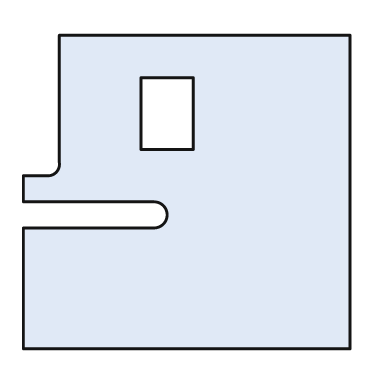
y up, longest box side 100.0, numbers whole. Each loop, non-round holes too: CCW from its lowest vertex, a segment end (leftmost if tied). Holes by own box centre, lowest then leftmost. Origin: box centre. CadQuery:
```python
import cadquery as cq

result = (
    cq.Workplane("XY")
    .moveTo(-50.0, -48.0)
    .lineTo(50.0, -48.0)
    .lineTo(50.0, 48.0)
    .lineTo(-39.0, 48.0)
    .lineTo(-39.0, 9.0)
    .threePointArc((-40.0, 6.0), (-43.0, 5.0))
    .lineTo(-50.0, 5.0)
    .lineTo(-50.0, -3.0)
    .lineTo(-10.0, -3.0)
    .threePointArc((-6.0, -7.0), (-10.0, -11.0))
    .lineTo(-50.0, -11.0)
    .close()
    .moveTo(-14.0, 13.0)
    .lineTo(2.0, 13.0)
    .lineTo(2.0, 35.0)
    .lineTo(-14.0, 35.0)
    .close()
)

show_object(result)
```